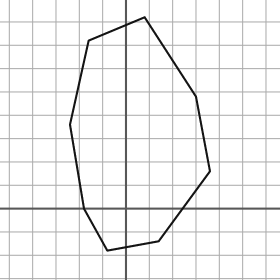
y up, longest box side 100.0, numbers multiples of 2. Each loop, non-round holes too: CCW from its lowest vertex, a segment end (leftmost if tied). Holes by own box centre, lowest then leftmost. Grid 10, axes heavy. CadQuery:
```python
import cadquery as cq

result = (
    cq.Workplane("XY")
    .moveTo(-8.0, -18.0)
    .lineTo(14.0, -14.0)
    .lineTo(36.0, 16.0)
    .lineTo(30.0, 48.0)
    .lineTo(8.0, 82.0)
    .lineTo(-16.0, 72.0)
    .lineTo(-24.0, 36.0)
    .lineTo(-18.0, 0.0)
    .close()
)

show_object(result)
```